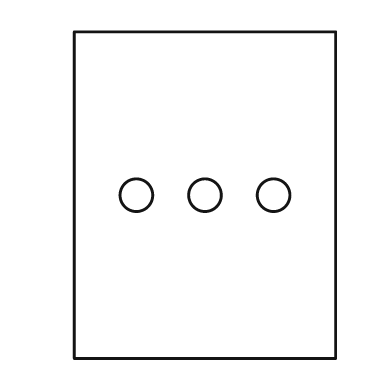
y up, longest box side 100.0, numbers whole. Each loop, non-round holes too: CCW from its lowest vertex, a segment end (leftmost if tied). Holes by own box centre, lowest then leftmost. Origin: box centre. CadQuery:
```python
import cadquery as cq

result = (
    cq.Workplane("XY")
    .moveTo(-40.0, -50.0)
    .lineTo(40.0, -50.0)
    .lineTo(40.0, 50.0)
    .lineTo(-40.0, 50.0)
    .close()
    .moveTo(-21.0, 0.0)
    .circle(5.0)
    .moveTo(0.0, 0.0)
    .circle(5.0)
    .moveTo(21.0, 0.0)
    .circle(5.0)
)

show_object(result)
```